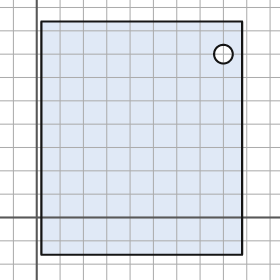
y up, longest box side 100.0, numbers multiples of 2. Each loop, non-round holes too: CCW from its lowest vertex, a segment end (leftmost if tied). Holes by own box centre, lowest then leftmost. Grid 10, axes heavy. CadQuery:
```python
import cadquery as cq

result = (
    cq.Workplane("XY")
    .moveTo(2.0, -16.0)
    .lineTo(88.0, -16.0)
    .lineTo(88.0, 84.0)
    .lineTo(2.0, 84.0)
    .close()
    .moveTo(80.0, 70.0)
    .circle(4.0)
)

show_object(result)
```